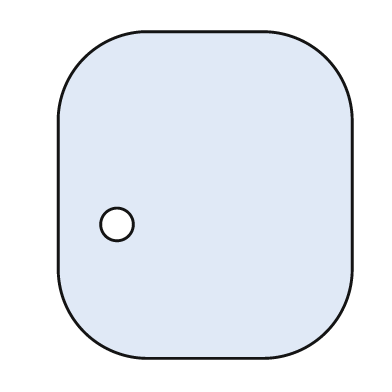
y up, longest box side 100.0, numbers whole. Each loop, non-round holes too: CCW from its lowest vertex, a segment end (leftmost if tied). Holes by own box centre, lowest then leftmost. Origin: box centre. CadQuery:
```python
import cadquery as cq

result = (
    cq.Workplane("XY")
    .moveTo(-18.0, -50.0)
    .lineTo(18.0, -50.0)
    .threePointArc((37.0, -42.0), (45.0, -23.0))
    .lineTo(45.0, 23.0)
    .threePointArc((37.0, 42.0), (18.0, 50.0))
    .lineTo(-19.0, 50.0)
    .threePointArc((-37.0, 42.0), (-45.0, 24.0))
    .lineTo(-45.0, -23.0)
    .threePointArc((-37.0, -42.0), (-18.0, -50.0))
    .close()
    .moveTo(-27.0, -9.0)
    .circle(5.0)
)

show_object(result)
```